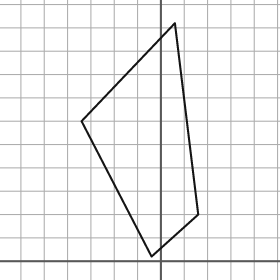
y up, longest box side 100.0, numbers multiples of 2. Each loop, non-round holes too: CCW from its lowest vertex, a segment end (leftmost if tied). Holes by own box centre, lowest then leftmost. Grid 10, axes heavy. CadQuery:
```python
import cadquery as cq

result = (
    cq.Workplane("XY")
    .moveTo(-4.0, 2.0)
    .lineTo(16.0, 20.0)
    .lineTo(6.0, 102.0)
    .lineTo(-34.0, 60.0)
    .close()
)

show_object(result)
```